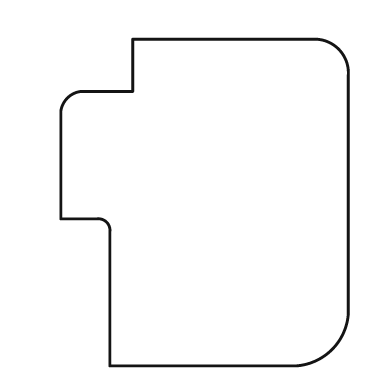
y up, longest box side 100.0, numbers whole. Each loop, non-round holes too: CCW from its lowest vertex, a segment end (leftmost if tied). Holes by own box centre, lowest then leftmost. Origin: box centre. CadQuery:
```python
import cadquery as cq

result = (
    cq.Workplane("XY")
    .moveTo(-29.0, -50.0)
    .lineTo(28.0, -50.0)
    .threePointArc((39.0, -45.0), (44.0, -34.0))
    .lineTo(44.0, 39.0)
    .threePointArc((41.0, 47.0), (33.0, 50.0))
    .lineTo(-22.0, 50.0)
    .lineTo(-22.0, 34.0)
    .lineTo(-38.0, 34.0)
    .threePointArc((-42.0, 32.0), (-44.0, 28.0))
    .lineTo(-44.0, -5.0)
    .lineTo(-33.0, -5.0)
    .threePointArc((-30.0, -6.0), (-29.0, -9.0))
    .close()
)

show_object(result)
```